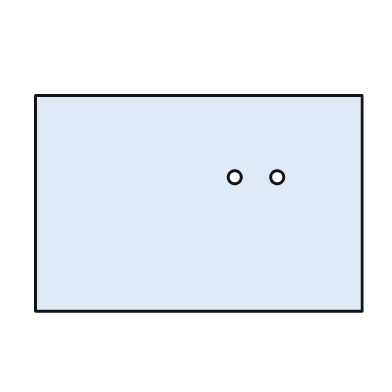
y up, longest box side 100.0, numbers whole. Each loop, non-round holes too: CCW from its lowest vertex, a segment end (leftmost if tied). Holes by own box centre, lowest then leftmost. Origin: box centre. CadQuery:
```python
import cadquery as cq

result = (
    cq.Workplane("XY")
    .moveTo(-50.0, -33.0)
    .lineTo(50.0, -33.0)
    .lineTo(50.0, 33.0)
    .lineTo(-50.0, 33.0)
    .close()
    .moveTo(11.0, 8.0)
    .circle(2.0)
    .moveTo(24.0, 8.0)
    .circle(2.0)
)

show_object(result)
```